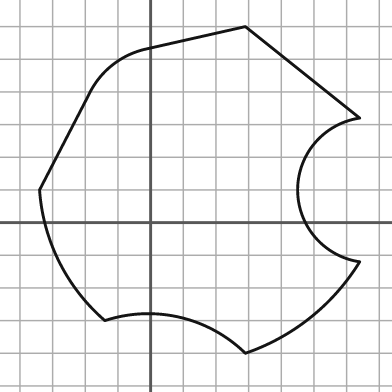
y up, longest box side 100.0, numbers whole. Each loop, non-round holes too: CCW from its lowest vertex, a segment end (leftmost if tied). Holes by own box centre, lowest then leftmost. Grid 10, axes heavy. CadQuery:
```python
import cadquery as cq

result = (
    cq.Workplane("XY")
    .moveTo(29.0, -40.0)
    .threePointArc((49.0, -29.0), (64.0, -12.0))
    .threePointArc((45.0, 10.0), (64.0, 32.0))
    .lineTo(29.0, 60.0)
    .lineTo(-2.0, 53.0)
    .threePointArc((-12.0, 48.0), (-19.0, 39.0))
    .lineTo(-34.0, 10.0)
    .threePointArc((-28.0, -12.0), (-14.0, -30.0))
    .threePointArc((9.0, -29.0), (29.0, -40.0))
    .close()
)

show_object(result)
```